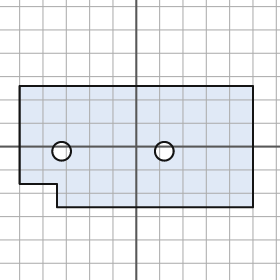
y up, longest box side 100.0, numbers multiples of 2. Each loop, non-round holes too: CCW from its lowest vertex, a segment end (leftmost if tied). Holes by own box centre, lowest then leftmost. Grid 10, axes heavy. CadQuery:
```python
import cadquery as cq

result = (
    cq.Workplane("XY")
    .moveTo(-34.0, -26.0)
    .lineTo(50.0, -26.0)
    .lineTo(50.0, 26.0)
    .lineTo(-50.0, 26.0)
    .lineTo(-50.0, -16.0)
    .lineTo(-34.0, -16.0)
    .close()
    .moveTo(-32.0, -2.0)
    .circle(4.0)
    .moveTo(12.0, -2.0)
    .circle(4.0)
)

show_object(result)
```